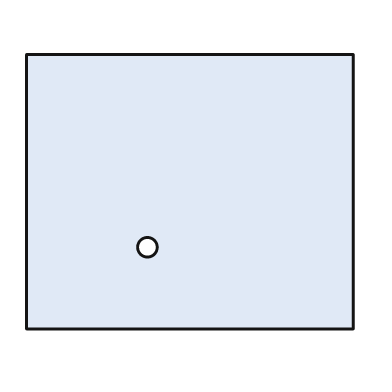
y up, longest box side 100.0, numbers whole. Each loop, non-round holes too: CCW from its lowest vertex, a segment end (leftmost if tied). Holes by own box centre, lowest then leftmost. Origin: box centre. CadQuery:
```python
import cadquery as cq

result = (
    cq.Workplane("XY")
    .moveTo(-50.0, -42.0)
    .lineTo(50.0, -42.0)
    .lineTo(50.0, 42.0)
    .lineTo(-50.0, 42.0)
    .close()
    .moveTo(-13.0, -17.0)
    .circle(3.0)
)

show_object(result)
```